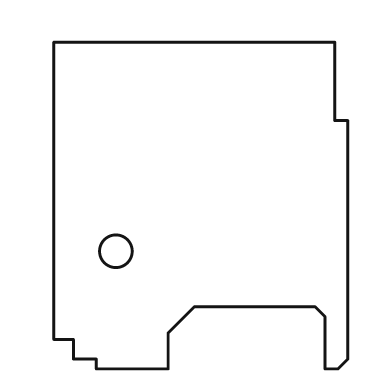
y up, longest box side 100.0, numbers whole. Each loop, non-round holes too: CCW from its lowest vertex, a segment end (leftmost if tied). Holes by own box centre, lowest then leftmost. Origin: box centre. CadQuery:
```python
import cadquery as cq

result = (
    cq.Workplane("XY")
    .moveTo(-32.0, -50.0)
    .lineTo(-10.0, -50.0)
    .lineTo(-10.0, -39.0)
    .lineTo(-2.0, -31.0)
    .lineTo(35.0, -31.0)
    .lineTo(38.0, -34.0)
    .lineTo(38.0, -50.0)
    .lineTo(42.0, -50.0)
    .lineTo(45.0, -47.0)
    .lineTo(45.0, 26.0)
    .lineTo(41.0, 26.0)
    .lineTo(41.0, 50.0)
    .lineTo(-45.0, 50.0)
    .lineTo(-45.0, -41.0)
    .lineTo(-39.0, -41.0)
    .lineTo(-39.0, -47.0)
    .lineTo(-32.0, -47.0)
    .close()
    .moveTo(-26.0, -14.0)
    .circle(5.0)
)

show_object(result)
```